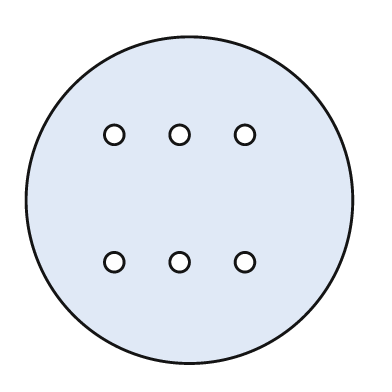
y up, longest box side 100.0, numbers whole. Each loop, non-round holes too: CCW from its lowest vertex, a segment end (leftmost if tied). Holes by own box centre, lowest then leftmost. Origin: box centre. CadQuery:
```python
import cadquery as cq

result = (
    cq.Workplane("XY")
    .moveTo(0.0, 0.0)
    .circle(50.0)
    .moveTo(-23.0, -19.0)
    .circle(3.0)
    .moveTo(-3.0, -19.0)
    .circle(3.0)
    .moveTo(17.0, -19.0)
    .circle(3.0)
    .moveTo(-23.0, 20.0)
    .circle(3.0)
    .moveTo(-3.0, 20.0)
    .circle(3.0)
    .moveTo(17.0, 20.0)
    .circle(3.0)
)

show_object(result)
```